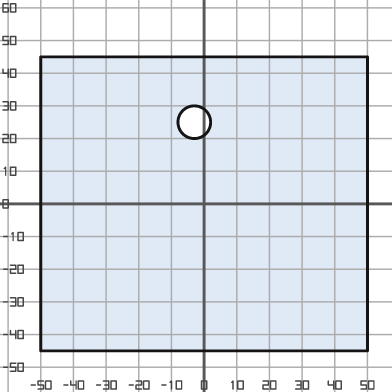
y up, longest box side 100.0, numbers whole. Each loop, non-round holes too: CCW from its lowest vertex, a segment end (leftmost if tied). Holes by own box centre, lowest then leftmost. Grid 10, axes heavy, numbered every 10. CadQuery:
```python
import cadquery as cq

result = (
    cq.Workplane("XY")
    .moveTo(-50.0, -45.0)
    .lineTo(50.0, -45.0)
    .lineTo(50.0, 45.0)
    .lineTo(-50.0, 45.0)
    .close()
    .moveTo(-3.0, 25.0)
    .circle(5.0)
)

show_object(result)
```